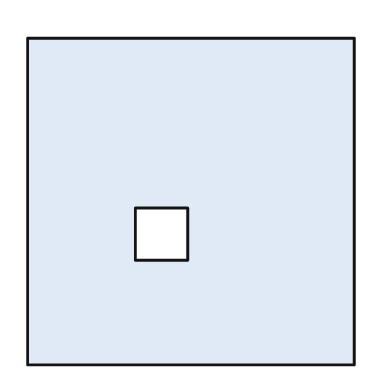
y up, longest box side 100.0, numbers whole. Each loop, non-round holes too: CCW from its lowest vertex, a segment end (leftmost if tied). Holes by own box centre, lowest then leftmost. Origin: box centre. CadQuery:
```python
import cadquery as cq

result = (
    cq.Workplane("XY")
    .moveTo(-50.0, -50.0)
    .lineTo(50.0, -50.0)
    .lineTo(50.0, 50.0)
    .lineTo(-50.0, 50.0)
    .close()
    .moveTo(-17.0, -18.0)
    .lineTo(-1.0, -18.0)
    .lineTo(-1.0, -2.0)
    .lineTo(-17.0, -2.0)
    .close()
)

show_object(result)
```